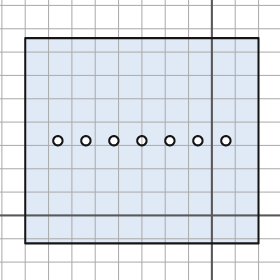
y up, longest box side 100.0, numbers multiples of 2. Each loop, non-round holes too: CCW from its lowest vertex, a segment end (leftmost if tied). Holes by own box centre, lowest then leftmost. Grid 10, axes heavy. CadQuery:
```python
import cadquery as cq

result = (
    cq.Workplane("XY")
    .moveTo(-80.0, -12.0)
    .lineTo(20.0, -12.0)
    .lineTo(20.0, 76.0)
    .lineTo(-80.0, 76.0)
    .close()
    .moveTo(-66.0, 32.0)
    .circle(2.0)
    .moveTo(-54.0, 32.0)
    .circle(2.0)
    .moveTo(-42.0, 32.0)
    .circle(2.0)
    .moveTo(-30.0, 32.0)
    .circle(2.0)
    .moveTo(-18.0, 32.0)
    .circle(2.0)
    .moveTo(-6.0, 32.0)
    .circle(2.0)
    .moveTo(6.0, 32.0)
    .circle(2.0)
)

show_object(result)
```